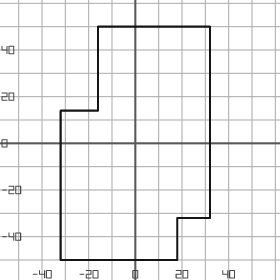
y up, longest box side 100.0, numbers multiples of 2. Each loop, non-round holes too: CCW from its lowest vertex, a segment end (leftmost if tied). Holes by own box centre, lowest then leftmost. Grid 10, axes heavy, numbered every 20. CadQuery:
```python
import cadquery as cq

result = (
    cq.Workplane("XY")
    .moveTo(-32.0, -50.0)
    .lineTo(18.0, -50.0)
    .lineTo(18.0, -32.0)
    .lineTo(32.0, -32.0)
    .lineTo(32.0, 50.0)
    .lineTo(-16.0, 50.0)
    .lineTo(-16.0, 14.0)
    .lineTo(-32.0, 14.0)
    .close()
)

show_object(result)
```